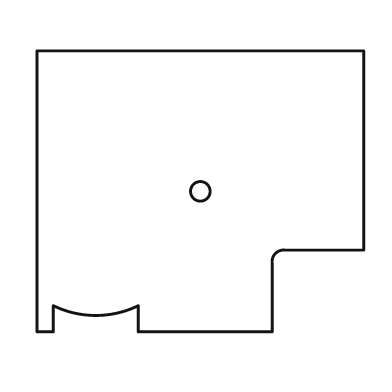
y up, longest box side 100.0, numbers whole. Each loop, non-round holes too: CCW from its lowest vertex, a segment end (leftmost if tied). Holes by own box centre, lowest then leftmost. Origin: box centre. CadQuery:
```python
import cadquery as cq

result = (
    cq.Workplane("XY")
    .moveTo(-50.0, -43.0)
    .lineTo(-45.0, -43.0)
    .lineTo(-45.0, -35.0)
    .threePointArc((-32.0, -38.0), (-19.0, -35.0))
    .lineTo(-19.0, -43.0)
    .lineTo(22.0, -43.0)
    .lineTo(22.0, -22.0)
    .threePointArc((23.0, -19.0), (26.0, -18.0))
    .lineTo(50.0, -18.0)
    .lineTo(50.0, 43.0)
    .lineTo(-50.0, 43.0)
    .close()
    .moveTo(0.0, 0.0)
    .circle(3.0)
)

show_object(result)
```